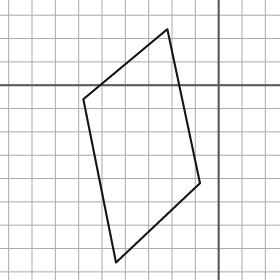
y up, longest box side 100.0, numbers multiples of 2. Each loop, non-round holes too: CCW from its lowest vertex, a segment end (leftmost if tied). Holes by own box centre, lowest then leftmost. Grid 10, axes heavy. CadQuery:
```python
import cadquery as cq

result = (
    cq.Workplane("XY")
    .moveTo(-44.0, -76.0)
    .lineTo(-8.0, -42.0)
    .lineTo(-22.0, 24.0)
    .lineTo(-58.0, -6.0)
    .close()
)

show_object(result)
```